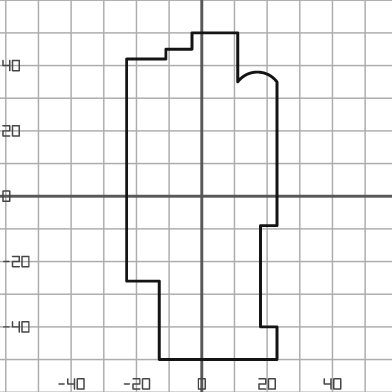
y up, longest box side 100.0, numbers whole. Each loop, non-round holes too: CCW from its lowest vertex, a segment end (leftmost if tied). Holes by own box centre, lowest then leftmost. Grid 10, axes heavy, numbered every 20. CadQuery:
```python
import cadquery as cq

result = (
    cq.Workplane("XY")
    .moveTo(-13.0, -50.0)
    .lineTo(23.0, -50.0)
    .lineTo(23.0, -40.0)
    .lineTo(18.0, -40.0)
    .lineTo(18.0, -9.0)
    .lineTo(23.0, -9.0)
    .lineTo(23.0, 35.0)
    .threePointArc((17.0, 38.0), (11.0, 35.0))
    .lineTo(11.0, 50.0)
    .lineTo(-3.0, 50.0)
    .lineTo(-3.0, 45.0)
    .lineTo(-11.0, 45.0)
    .lineTo(-11.0, 42.0)
    .lineTo(-23.0, 42.0)
    .lineTo(-23.0, -26.0)
    .lineTo(-13.0, -26.0)
    .close()
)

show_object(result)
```